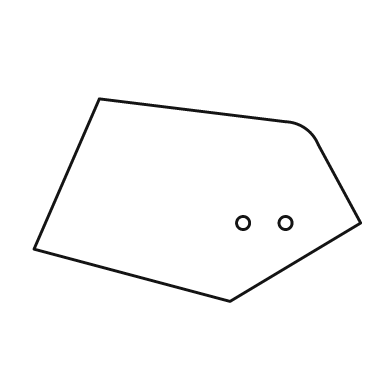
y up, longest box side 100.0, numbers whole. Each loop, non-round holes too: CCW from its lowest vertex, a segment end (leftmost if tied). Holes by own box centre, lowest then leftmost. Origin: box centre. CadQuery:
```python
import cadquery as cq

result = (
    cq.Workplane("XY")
    .moveTo(10.0, -31.0)
    .lineTo(50.0, -7.0)
    .lineTo(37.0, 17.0)
    .threePointArc((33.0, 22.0), (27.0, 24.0))
    .lineTo(-30.0, 31.0)
    .lineTo(-50.0, -15.0)
    .close()
    .moveTo(14.0, -7.0)
    .circle(2.0)
    .moveTo(27.0, -7.0)
    .circle(2.0)
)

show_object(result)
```